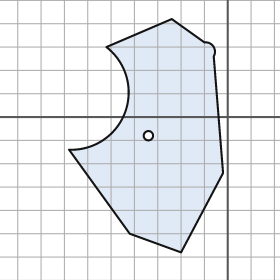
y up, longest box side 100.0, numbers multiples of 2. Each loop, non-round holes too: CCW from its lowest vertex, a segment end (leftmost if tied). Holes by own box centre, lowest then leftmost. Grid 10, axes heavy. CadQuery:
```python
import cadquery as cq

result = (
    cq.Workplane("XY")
    .moveTo(-20.0, -58.0)
    .lineTo(-2.0, -24.0)
    .lineTo(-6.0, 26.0)
    .threePointArc((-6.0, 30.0), (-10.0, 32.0))
    .lineTo(-24.0, 42.0)
    .lineTo(-52.0, 30.0)
    .threePointArc((-44.0, 2.0), (-68.0, -14.0))
    .lineTo(-42.0, -50.0)
    .close()
    .moveTo(-34.0, -8.0)
    .circle(2.0)
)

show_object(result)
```